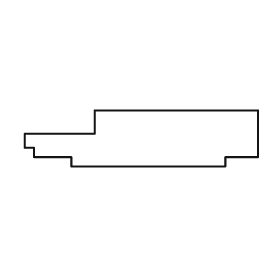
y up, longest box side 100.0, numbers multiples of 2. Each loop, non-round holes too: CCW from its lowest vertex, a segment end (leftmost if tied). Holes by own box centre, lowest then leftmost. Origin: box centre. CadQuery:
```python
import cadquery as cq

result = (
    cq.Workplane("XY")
    .moveTo(-30.0, -12.0)
    .lineTo(36.0, -12.0)
    .lineTo(36.0, -8.0)
    .lineTo(50.0, -8.0)
    .lineTo(50.0, 12.0)
    .lineTo(-20.0, 12.0)
    .lineTo(-20.0, 2.0)
    .lineTo(-50.0, 2.0)
    .lineTo(-50.0, -4.0)
    .lineTo(-46.0, -4.0)
    .lineTo(-46.0, -8.0)
    .lineTo(-30.0, -8.0)
    .close()
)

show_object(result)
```